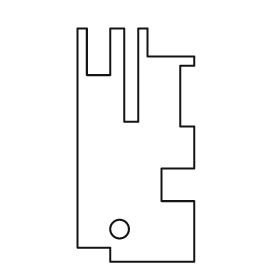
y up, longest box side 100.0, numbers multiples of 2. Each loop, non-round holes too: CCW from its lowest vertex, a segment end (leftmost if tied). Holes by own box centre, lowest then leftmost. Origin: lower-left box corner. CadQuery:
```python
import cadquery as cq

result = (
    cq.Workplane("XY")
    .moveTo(14.0, 0.0)
    .lineTo(50.0, 0.0)
    .lineTo(50.0, 26.0)
    .lineTo(36.0, 26.0)
    .lineTo(36.0, 40.0)
    .lineTo(50.0, 40.0)
    .lineTo(50.0, 58.0)
    .lineTo(44.0, 58.0)
    .lineTo(44.0, 84.0)
    .lineTo(50.0, 84.0)
    .lineTo(50.0, 88.0)
    .lineTo(30.0, 88.0)
    .lineTo(30.0, 100.0)
    .lineTo(26.0, 100.0)
    .lineTo(26.0, 60.0)
    .lineTo(20.0, 60.0)
    .lineTo(20.0, 100.0)
    .lineTo(14.0, 100.0)
    .lineTo(14.0, 80.0)
    .lineTo(4.0, 80.0)
    .lineTo(4.0, 100.0)
    .lineTo(0.0, 100.0)
    .lineTo(0.0, 6.0)
    .lineTo(14.0, 6.0)
    .close()
    .moveTo(18.0, 14.0)
    .circle(4.0)
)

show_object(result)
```